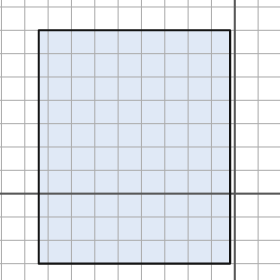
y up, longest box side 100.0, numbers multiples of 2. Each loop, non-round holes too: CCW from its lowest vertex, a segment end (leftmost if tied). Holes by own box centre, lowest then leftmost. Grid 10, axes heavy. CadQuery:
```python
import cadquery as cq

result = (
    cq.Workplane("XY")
    .moveTo(-84.0, -30.0)
    .lineTo(-2.0, -30.0)
    .lineTo(-2.0, 70.0)
    .lineTo(-84.0, 70.0)
    .close()
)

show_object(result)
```